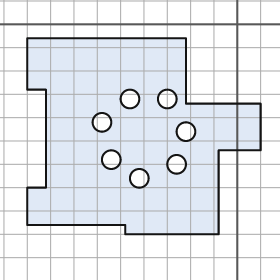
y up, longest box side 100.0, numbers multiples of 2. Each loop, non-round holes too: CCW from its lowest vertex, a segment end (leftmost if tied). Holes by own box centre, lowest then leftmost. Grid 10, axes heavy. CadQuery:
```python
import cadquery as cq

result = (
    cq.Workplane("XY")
    .moveTo(-48.0, -90.0)
    .lineTo(-8.0, -90.0)
    .lineTo(-8.0, -54.0)
    .lineTo(10.0, -54.0)
    .lineTo(10.0, -34.0)
    .lineTo(-22.0, -34.0)
    .lineTo(-22.0, -6.0)
    .lineTo(-90.0, -6.0)
    .lineTo(-90.0, -28.0)
    .lineTo(-82.0, -28.0)
    .lineTo(-82.0, -70.0)
    .lineTo(-90.0, -70.0)
    .lineTo(-90.0, -86.0)
    .lineTo(-48.0, -86.0)
    .close()
    .moveTo(-42.0, -66.0)
    .circle(4.0)
    .moveTo(-26.0, -60.0)
    .circle(4.0)
    .moveTo(-54.0, -58.0)
    .circle(4.0)
    .moveTo(-22.0, -46.0)
    .circle(4.0)
    .moveTo(-58.0, -42.0)
    .circle(4.0)
    .moveTo(-46.0, -32.0)
    .circle(4.0)
    .moveTo(-30.0, -32.0)
    .circle(4.0)
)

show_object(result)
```